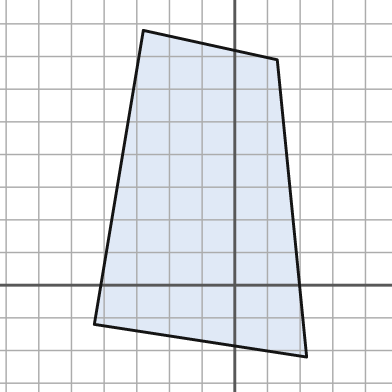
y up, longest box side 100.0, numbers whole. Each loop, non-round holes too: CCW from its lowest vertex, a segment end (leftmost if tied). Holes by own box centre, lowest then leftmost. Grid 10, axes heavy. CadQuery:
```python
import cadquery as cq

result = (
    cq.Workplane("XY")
    .moveTo(22.0, -22.0)
    .lineTo(13.0, 69.0)
    .lineTo(-28.0, 78.0)
    .lineTo(-43.0, -12.0)
    .close()
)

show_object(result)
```